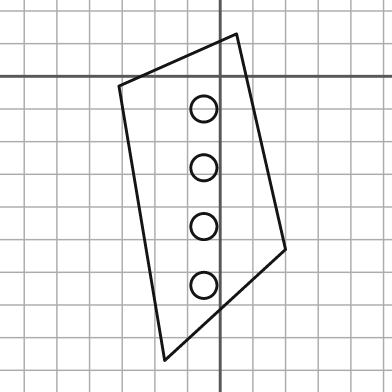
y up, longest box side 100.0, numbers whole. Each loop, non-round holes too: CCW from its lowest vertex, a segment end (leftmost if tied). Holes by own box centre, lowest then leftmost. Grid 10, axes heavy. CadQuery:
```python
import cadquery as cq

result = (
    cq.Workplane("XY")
    .moveTo(-17.0, -87.0)
    .lineTo(20.0, -53.0)
    .lineTo(5.0, 13.0)
    .lineTo(-31.0, -3.0)
    .close()
    .moveTo(-5.0, -64.0)
    .circle(4.0)
    .moveTo(-5.0, -46.0)
    .circle(4.0)
    .moveTo(-5.0, -28.0)
    .circle(4.0)
    .moveTo(-5.0, -10.0)
    .circle(4.0)
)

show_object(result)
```